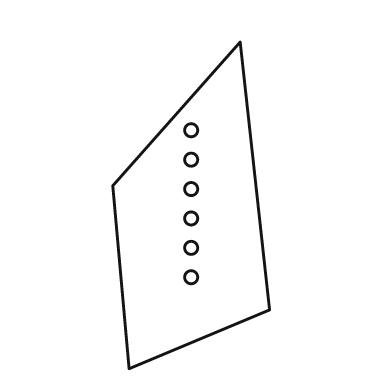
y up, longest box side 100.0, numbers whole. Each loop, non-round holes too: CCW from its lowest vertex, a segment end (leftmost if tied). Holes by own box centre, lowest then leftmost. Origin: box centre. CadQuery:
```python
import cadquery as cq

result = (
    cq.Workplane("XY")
    .moveTo(-19.0, -50.0)
    .lineTo(24.0, -32.0)
    .lineTo(15.0, 50.0)
    .lineTo(-24.0, 6.0)
    .close()
    .moveTo(0.0, -22.0)
    .circle(2.0)
    .moveTo(0.0, -13.0)
    .circle(2.0)
    .moveTo(0.0, -4.0)
    .circle(2.0)
    .moveTo(0.0, 5.0)
    .circle(2.0)
    .moveTo(0.0, 14.0)
    .circle(2.0)
    .moveTo(0.0, 23.0)
    .circle(2.0)
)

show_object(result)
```